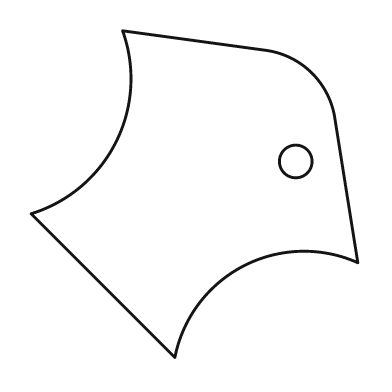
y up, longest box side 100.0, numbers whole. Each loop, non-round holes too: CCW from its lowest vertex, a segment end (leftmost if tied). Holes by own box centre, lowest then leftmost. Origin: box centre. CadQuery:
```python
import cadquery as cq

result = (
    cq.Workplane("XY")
    .moveTo(-6.0, -50.0)
    .threePointArc((15.0, -22.0), (50.0, -21.0))
    .lineTo(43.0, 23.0)
    .threePointArc((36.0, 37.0), (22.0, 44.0))
    .lineTo(-22.0, 50.0)
    .threePointArc((-24.0, 16.0), (-50.0, -6.0))
    .close()
    .moveTo(31.0, 10.0)
    .circle(5.0)
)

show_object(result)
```